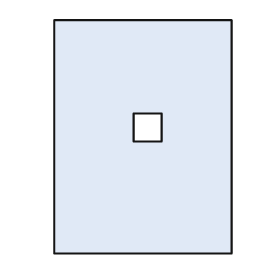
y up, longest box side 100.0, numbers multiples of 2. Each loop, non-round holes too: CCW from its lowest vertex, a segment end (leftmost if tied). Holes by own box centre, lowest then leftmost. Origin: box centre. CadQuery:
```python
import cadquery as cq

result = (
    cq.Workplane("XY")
    .moveTo(-38.0, -50.0)
    .lineTo(38.0, -50.0)
    .lineTo(38.0, 50.0)
    .lineTo(-38.0, 50.0)
    .close()
    .moveTo(-4.0, -2.0)
    .lineTo(8.0, -2.0)
    .lineTo(8.0, 10.0)
    .lineTo(-4.0, 10.0)
    .close()
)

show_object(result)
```